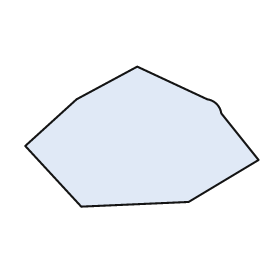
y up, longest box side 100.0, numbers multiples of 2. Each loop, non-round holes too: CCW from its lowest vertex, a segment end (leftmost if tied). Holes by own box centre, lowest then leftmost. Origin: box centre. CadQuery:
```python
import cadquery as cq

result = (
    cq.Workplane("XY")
    .moveTo(-26.0, -30.0)
    .lineTo(20.0, -28.0)
    .lineTo(50.0, -10.0)
    .lineTo(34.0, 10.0)
    .threePointArc((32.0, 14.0), (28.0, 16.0))
    .lineTo(-2.0, 30.0)
    .lineTo(-28.0, 16.0)
    .lineTo(-50.0, -4.0)
    .close()
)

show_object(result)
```